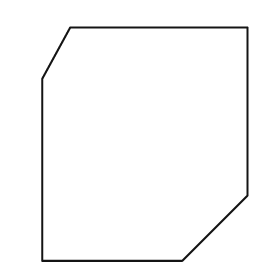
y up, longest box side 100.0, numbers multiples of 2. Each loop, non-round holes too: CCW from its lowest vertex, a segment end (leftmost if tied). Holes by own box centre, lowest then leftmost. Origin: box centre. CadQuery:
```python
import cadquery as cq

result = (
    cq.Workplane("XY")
    .moveTo(-44.0, -50.0)
    .lineTo(16.0, -50.0)
    .lineTo(44.0, -22.0)
    .lineTo(44.0, 50.0)
    .lineTo(-32.0, 50.0)
    .lineTo(-44.0, 28.0)
    .close()
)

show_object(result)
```